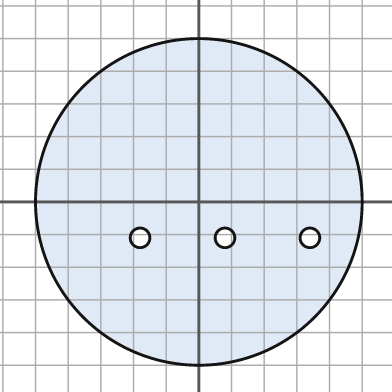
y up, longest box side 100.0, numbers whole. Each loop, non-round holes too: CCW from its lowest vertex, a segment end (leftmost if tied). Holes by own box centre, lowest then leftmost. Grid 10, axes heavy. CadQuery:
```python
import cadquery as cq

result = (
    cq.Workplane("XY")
    .moveTo(0.0, 0.0)
    .circle(50.0)
    .moveTo(-18.0, -11.0)
    .circle(3.0)
    .moveTo(8.0, -11.0)
    .circle(3.0)
    .moveTo(34.0, -11.0)
    .circle(3.0)
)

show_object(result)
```